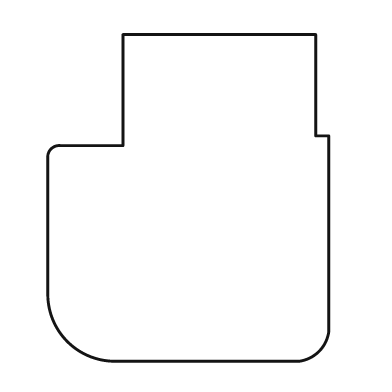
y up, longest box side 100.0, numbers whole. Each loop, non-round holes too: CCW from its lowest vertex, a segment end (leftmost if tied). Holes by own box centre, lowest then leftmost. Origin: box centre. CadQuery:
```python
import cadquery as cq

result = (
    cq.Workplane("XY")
    .moveTo(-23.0, -50.0)
    .lineTo(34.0, -50.0)
    .threePointArc((40.0, -47.0), (43.0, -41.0))
    .lineTo(43.0, 19.0)
    .lineTo(39.0, 19.0)
    .lineTo(39.0, 50.0)
    .lineTo(-20.0, 50.0)
    .lineTo(-20.0, 16.0)
    .lineTo(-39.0, 16.0)
    .threePointArc((-42.0, 15.0), (-43.0, 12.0))
    .lineTo(-43.0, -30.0)
    .threePointArc((-37.0, -44.0), (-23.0, -50.0))
    .close()
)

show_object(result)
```